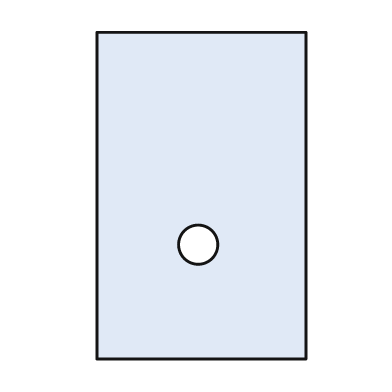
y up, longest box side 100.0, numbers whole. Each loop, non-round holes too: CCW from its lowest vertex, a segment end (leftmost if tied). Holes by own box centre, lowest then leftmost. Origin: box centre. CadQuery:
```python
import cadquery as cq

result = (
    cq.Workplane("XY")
    .moveTo(-32.0, -50.0)
    .lineTo(32.0, -50.0)
    .lineTo(32.0, 50.0)
    .lineTo(-32.0, 50.0)
    .close()
    .moveTo(-1.0, -15.0)
    .circle(6.0)
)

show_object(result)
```